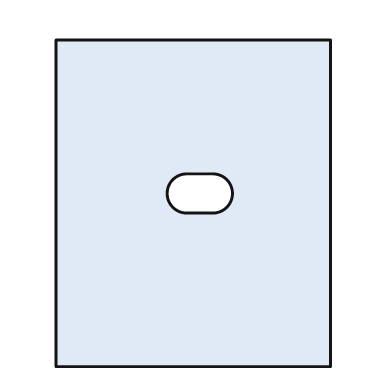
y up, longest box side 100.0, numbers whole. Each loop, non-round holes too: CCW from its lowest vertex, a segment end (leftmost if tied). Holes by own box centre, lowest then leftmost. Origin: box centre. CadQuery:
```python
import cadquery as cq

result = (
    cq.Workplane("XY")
    .moveTo(-42.0, -50.0)
    .lineTo(42.0, -50.0)
    .lineTo(42.0, 50.0)
    .lineTo(-42.0, 50.0)
    .close()
    .moveTo(-2.0, -3.0)
    .lineTo(6.0, -3.0)
    .threePointArc((12.0, 3.0), (6.0, 9.0))
    .lineTo(-2.0, 9.0)
    .threePointArc((-8.0, 3.0), (-2.0, -3.0))
    .close()
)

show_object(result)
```